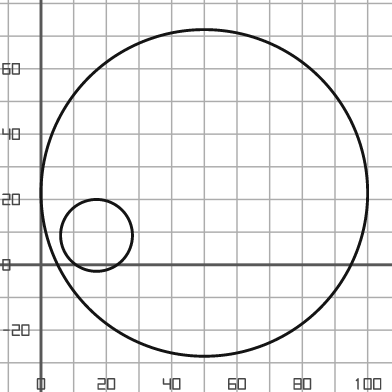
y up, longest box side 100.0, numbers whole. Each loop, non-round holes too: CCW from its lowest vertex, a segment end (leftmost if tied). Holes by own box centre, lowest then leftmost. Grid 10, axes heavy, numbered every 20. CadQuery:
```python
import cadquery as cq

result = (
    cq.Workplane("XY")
    .moveTo(50.0, 22.0)
    .circle(50.0)
    .moveTo(17.0, 9.0)
    .circle(11.0)
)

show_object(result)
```